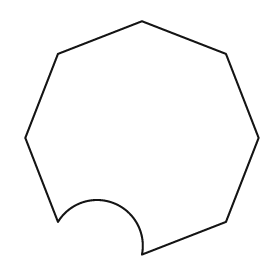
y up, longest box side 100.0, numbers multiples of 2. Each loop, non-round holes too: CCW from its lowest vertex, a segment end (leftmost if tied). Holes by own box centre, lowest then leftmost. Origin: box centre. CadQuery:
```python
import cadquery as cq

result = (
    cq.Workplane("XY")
    .moveTo(0.0, -50.0)
    .lineTo(36.0, -36.0)
    .lineTo(50.0, 0.0)
    .lineTo(36.0, 36.0)
    .lineTo(0.0, 50.0)
    .lineTo(-36.0, 36.0)
    .lineTo(-50.0, 0.0)
    .lineTo(-36.0, -36.0)
    .threePointArc((-12.0, -28.0), (0.0, -50.0))
    .close()
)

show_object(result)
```